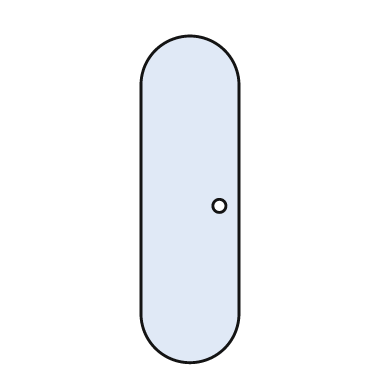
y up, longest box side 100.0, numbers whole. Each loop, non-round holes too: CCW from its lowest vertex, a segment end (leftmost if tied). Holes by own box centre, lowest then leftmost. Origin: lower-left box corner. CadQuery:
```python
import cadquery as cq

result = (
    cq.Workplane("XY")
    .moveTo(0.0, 15.0)
    .threePointArc((15.0, 0.0), (30.0, 15.0))
    .lineTo(30.0, 85.0)
    .threePointArc((15.0, 100.0), (0.0, 85.0))
    .close()
    .moveTo(24.0, 48.0)
    .circle(2.0)
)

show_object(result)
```